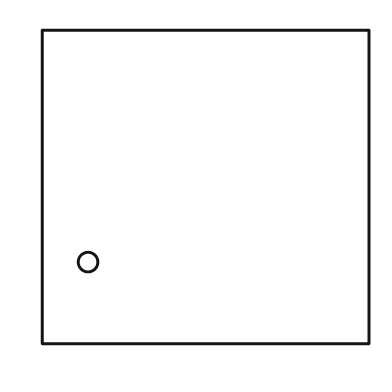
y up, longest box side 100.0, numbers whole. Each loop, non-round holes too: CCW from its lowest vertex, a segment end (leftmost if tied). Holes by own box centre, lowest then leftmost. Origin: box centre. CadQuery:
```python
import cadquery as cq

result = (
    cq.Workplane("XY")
    .moveTo(-50.0, -48.0)
    .lineTo(50.0, -48.0)
    .lineTo(50.0, 48.0)
    .lineTo(-50.0, 48.0)
    .close()
    .moveTo(-36.0, -23.0)
    .circle(3.0)
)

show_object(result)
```